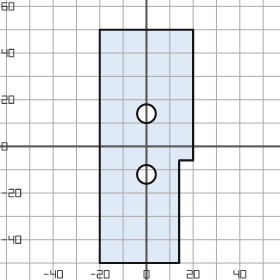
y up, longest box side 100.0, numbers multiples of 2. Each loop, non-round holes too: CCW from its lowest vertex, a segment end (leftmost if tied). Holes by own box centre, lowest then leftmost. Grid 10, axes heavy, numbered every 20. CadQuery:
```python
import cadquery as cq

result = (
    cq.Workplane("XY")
    .moveTo(-20.0, -50.0)
    .lineTo(14.0, -50.0)
    .lineTo(14.0, -6.0)
    .lineTo(20.0, -6.0)
    .lineTo(20.0, 50.0)
    .lineTo(-20.0, 50.0)
    .close()
    .moveTo(0.0, -12.0)
    .circle(4.0)
    .moveTo(0.0, 14.0)
    .circle(4.0)
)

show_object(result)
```